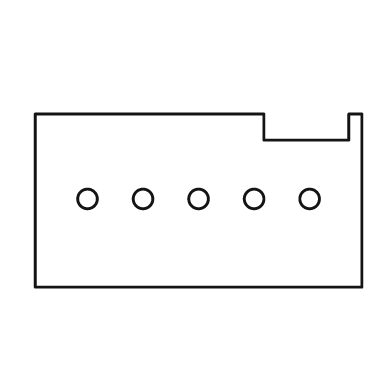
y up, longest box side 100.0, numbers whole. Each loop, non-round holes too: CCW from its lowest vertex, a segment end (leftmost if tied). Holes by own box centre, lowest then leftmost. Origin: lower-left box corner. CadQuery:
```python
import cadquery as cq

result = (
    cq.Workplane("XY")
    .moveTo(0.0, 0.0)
    .lineTo(100.0, 0.0)
    .lineTo(100.0, 53.0)
    .lineTo(96.0, 53.0)
    .lineTo(96.0, 45.0)
    .lineTo(70.0, 45.0)
    .lineTo(70.0, 53.0)
    .lineTo(0.0, 53.0)
    .close()
    .moveTo(16.0, 27.0)
    .circle(3.0)
    .moveTo(33.0, 27.0)
    .circle(3.0)
    .moveTo(50.0, 27.0)
    .circle(3.0)
    .moveTo(67.0, 27.0)
    .circle(3.0)
    .moveTo(84.0, 27.0)
    .circle(3.0)
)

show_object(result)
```